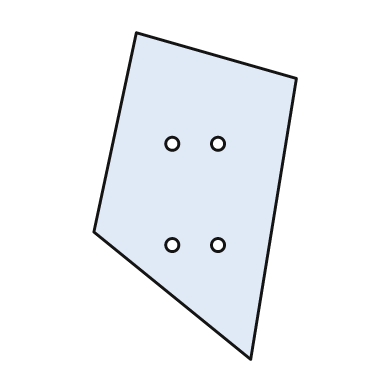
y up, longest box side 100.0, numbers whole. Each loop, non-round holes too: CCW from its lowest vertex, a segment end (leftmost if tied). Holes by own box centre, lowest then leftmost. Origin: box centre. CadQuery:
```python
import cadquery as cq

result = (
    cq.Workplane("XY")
    .moveTo(17.0, -50.0)
    .lineTo(31.0, 36.0)
    .lineTo(-18.0, 50.0)
    .lineTo(-31.0, -11.0)
    .close()
    .moveTo(-7.0, -15.0)
    .circle(2.0)
    .moveTo(7.0, -15.0)
    .circle(2.0)
    .moveTo(-7.0, 16.0)
    .circle(2.0)
    .moveTo(7.0, 16.0)
    .circle(2.0)
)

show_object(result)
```